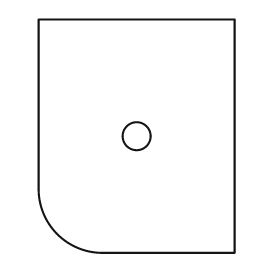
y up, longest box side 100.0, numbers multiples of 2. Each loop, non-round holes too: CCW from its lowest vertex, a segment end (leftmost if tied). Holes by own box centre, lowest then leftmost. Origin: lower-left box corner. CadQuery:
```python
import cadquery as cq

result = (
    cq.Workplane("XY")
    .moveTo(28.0, 0.0)
    .lineTo(84.0, 0.0)
    .lineTo(84.0, 100.0)
    .lineTo(0.0, 100.0)
    .lineTo(0.0, 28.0)
    .threePointArc((8.0, 8.0), (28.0, 0.0))
    .close()
    .moveTo(42.0, 50.0)
    .circle(6.0)
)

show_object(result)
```